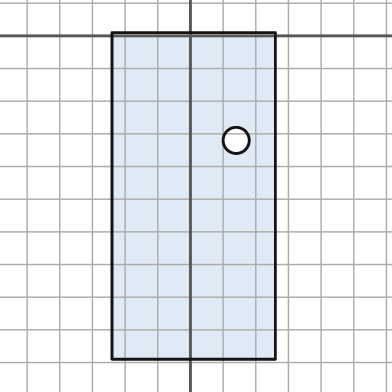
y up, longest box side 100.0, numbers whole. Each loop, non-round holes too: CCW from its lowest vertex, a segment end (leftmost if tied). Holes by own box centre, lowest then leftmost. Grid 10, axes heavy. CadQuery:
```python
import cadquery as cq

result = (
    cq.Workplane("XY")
    .moveTo(-24.0, -99.0)
    .lineTo(26.0, -99.0)
    .lineTo(26.0, 1.0)
    .lineTo(-24.0, 1.0)
    .close()
    .moveTo(14.0, -32.0)
    .circle(4.0)
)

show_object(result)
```